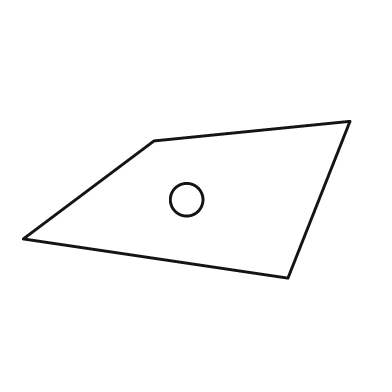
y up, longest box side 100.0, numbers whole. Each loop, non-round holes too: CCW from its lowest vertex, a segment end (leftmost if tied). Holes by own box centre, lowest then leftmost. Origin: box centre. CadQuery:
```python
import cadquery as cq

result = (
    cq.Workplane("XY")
    .moveTo(31.0, -24.0)
    .lineTo(50.0, 24.0)
    .lineTo(-10.0, 18.0)
    .lineTo(-50.0, -12.0)
    .close()
    .moveTo(0.0, 0.0)
    .circle(5.0)
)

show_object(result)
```